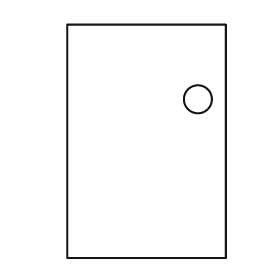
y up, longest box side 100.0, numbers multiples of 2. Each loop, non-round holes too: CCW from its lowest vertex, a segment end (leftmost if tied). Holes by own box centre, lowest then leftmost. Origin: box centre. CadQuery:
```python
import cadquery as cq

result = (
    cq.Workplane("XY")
    .moveTo(-34.0, -50.0)
    .lineTo(34.0, -50.0)
    .lineTo(34.0, 50.0)
    .lineTo(-34.0, 50.0)
    .close()
    .moveTo(22.0, 18.0)
    .circle(6.0)
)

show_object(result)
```